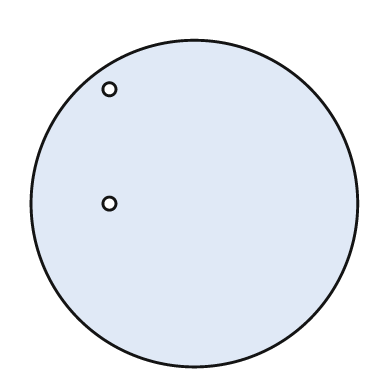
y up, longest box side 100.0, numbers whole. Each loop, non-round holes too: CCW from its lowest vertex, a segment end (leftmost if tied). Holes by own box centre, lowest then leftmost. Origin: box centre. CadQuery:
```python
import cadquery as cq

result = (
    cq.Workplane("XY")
    .moveTo(0.0, 0.0)
    .circle(50.0)
    .moveTo(-26.0, 0.0)
    .circle(2.0)
    .moveTo(-26.0, 35.0)
    .circle(2.0)
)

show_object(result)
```